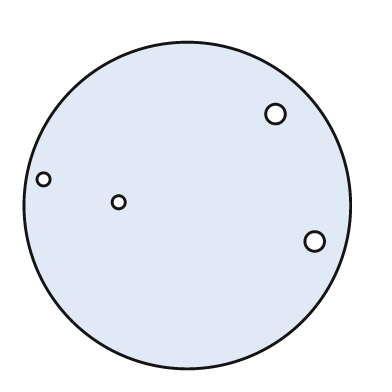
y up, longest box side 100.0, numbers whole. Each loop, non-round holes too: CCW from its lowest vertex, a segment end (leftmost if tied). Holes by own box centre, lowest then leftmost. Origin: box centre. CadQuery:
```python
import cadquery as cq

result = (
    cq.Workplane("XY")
    .moveTo(0.0, 0.0)
    .circle(50.0)
    .moveTo(39.0, -11.0)
    .circle(3.0)
    .moveTo(-21.0, 1.0)
    .circle(2.0)
    .moveTo(-44.0, 8.0)
    .circle(2.0)
    .moveTo(27.0, 28.0)
    .circle(3.0)
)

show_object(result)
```